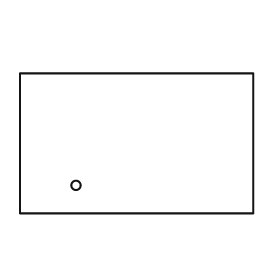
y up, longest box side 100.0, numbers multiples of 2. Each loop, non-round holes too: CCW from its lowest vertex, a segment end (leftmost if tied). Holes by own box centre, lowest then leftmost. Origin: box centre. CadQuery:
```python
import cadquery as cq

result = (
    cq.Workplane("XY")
    .moveTo(-50.0, -30.0)
    .lineTo(50.0, -30.0)
    .lineTo(50.0, 30.0)
    .lineTo(-50.0, 30.0)
    .close()
    .moveTo(-26.0, -18.0)
    .circle(2.0)
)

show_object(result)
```